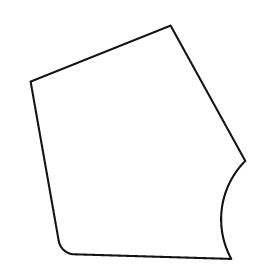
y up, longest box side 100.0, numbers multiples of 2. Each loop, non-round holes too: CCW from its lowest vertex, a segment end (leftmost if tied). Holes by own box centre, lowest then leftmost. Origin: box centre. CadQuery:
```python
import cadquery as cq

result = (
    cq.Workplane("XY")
    .moveTo(40.0, -50.0)
    .threePointArc((36.0, -28.0), (46.0, -8.0))
    .lineTo(14.0, 50.0)
    .lineTo(-46.0, 26.0)
    .lineTo(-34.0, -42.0)
    .threePointArc((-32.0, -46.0), (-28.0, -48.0))
    .close()
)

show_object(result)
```